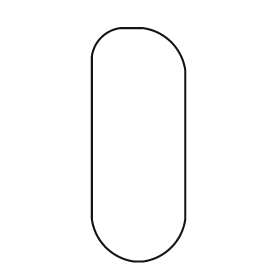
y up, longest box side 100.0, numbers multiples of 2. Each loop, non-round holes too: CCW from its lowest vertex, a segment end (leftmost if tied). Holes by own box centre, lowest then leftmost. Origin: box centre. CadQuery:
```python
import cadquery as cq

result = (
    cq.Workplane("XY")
    .moveTo(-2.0, -50.0)
    .lineTo(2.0, -50.0)
    .threePointArc((14.0, -44.0), (20.0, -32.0))
    .lineTo(20.0, 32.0)
    .threePointArc((14.0, 44.0), (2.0, 50.0))
    .lineTo(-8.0, 50.0)
    .threePointArc((-16.0, 46.0), (-20.0, 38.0))
    .lineTo(-20.0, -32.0)
    .threePointArc((-14.0, -44.0), (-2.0, -50.0))
    .close()
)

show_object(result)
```